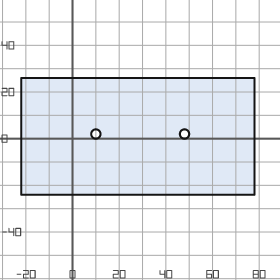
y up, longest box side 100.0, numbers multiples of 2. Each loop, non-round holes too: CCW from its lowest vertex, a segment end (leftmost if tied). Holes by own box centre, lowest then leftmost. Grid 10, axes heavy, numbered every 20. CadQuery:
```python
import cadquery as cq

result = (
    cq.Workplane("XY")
    .moveTo(-22.0, -24.0)
    .lineTo(78.0, -24.0)
    .lineTo(78.0, 26.0)
    .lineTo(-22.0, 26.0)
    .close()
    .moveTo(10.0, 2.0)
    .circle(2.0)
    .moveTo(48.0, 2.0)
    .circle(2.0)
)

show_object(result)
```